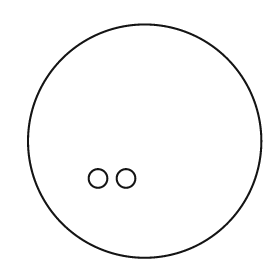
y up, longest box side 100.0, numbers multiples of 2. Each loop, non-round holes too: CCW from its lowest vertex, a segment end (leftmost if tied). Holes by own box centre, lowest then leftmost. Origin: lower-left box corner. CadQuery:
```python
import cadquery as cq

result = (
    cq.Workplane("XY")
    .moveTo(50.0, 50.0)
    .circle(50.0)
    .moveTo(30.0, 34.0)
    .circle(4.0)
    .moveTo(42.0, 34.0)
    .circle(4.0)
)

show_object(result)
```